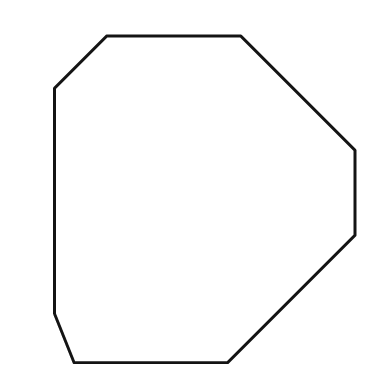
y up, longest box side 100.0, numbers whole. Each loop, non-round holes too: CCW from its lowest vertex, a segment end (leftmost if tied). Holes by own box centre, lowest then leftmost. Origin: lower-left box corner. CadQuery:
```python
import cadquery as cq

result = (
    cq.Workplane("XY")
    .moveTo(6.0, 0.0)
    .lineTo(53.0, 0.0)
    .lineTo(92.0, 39.0)
    .lineTo(92.0, 65.0)
    .lineTo(57.0, 100.0)
    .lineTo(16.0, 100.0)
    .lineTo(0.0, 84.0)
    .lineTo(0.0, 15.0)
    .close()
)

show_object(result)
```